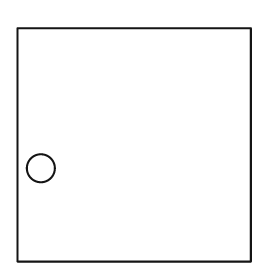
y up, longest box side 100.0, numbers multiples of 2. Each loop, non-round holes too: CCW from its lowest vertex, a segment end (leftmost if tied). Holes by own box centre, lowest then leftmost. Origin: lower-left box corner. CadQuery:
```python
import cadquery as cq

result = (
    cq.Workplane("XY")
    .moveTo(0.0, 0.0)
    .lineTo(100.0, 0.0)
    .lineTo(100.0, 100.0)
    .lineTo(0.0, 100.0)
    .close()
    .moveTo(10.0, 40.0)
    .circle(6.0)
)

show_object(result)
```